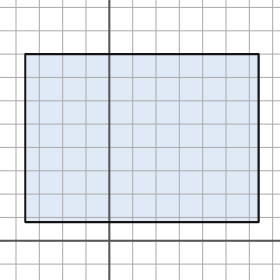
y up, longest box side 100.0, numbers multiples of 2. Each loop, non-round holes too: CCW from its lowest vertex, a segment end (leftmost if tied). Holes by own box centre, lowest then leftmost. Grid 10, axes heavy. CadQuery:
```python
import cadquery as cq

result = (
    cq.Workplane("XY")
    .moveTo(-36.0, 8.0)
    .lineTo(64.0, 8.0)
    .lineTo(64.0, 80.0)
    .lineTo(-36.0, 80.0)
    .close()
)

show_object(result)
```